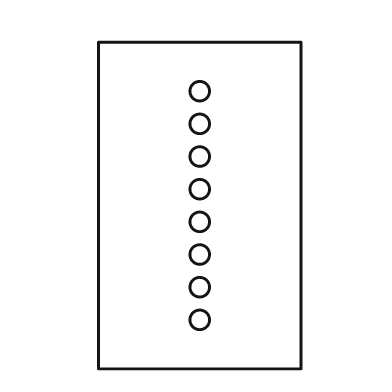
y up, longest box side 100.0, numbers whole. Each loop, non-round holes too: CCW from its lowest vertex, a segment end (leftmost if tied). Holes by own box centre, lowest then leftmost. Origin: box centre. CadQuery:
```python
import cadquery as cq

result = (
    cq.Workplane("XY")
    .moveTo(-31.0, -50.0)
    .lineTo(31.0, -50.0)
    .lineTo(31.0, 50.0)
    .lineTo(-31.0, 50.0)
    .close()
    .moveTo(0.0, -35.0)
    .circle(3.0)
    .moveTo(0.0, -25.0)
    .circle(3.0)
    .moveTo(0.0, -15.0)
    .circle(3.0)
    .moveTo(0.0, -5.0)
    .circle(3.0)
    .moveTo(0.0, 5.0)
    .circle(3.0)
    .moveTo(0.0, 15.0)
    .circle(3.0)
    .moveTo(0.0, 25.0)
    .circle(3.0)
    .moveTo(0.0, 35.0)
    .circle(3.0)
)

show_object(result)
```